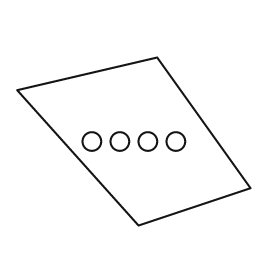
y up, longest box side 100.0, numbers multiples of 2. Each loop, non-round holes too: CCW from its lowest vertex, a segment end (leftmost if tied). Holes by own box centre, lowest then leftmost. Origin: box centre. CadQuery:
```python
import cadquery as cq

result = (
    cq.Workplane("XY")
    .moveTo(2.0, -36.0)
    .lineTo(50.0, -20.0)
    .lineTo(10.0, 36.0)
    .lineTo(-50.0, 22.0)
    .close()
    .moveTo(-18.0, 0.0)
    .circle(4.0)
    .moveTo(-6.0, 0.0)
    .circle(4.0)
    .moveTo(6.0, 0.0)
    .circle(4.0)
    .moveTo(18.0, 0.0)
    .circle(4.0)
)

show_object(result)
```